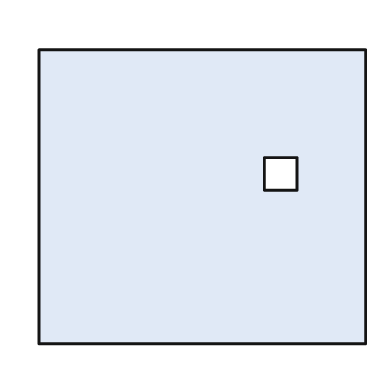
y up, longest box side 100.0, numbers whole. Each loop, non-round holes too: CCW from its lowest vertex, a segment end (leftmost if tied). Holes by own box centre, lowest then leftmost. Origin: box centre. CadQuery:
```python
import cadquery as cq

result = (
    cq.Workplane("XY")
    .moveTo(-50.0, -45.0)
    .lineTo(50.0, -45.0)
    .lineTo(50.0, 45.0)
    .lineTo(-50.0, 45.0)
    .close()
    .moveTo(19.0, 2.0)
    .lineTo(29.0, 2.0)
    .lineTo(29.0, 12.0)
    .lineTo(19.0, 12.0)
    .close()
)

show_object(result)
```